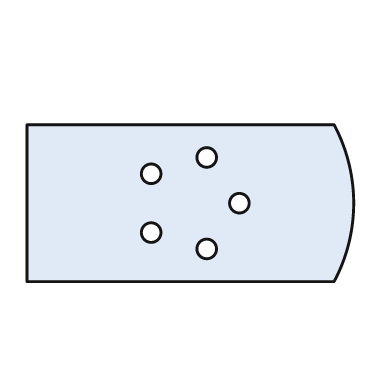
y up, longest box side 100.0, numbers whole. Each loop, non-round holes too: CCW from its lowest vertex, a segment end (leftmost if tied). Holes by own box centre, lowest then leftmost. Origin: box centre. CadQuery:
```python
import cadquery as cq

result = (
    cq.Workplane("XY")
    .moveTo(-50.0, -24.0)
    .lineTo(44.0, -24.0)
    .threePointArc((50.0, 0.0), (44.0, 24.0))
    .lineTo(-50.0, 24.0)
    .close()
    .moveTo(5.0, -14.0)
    .circle(3.0)
    .moveTo(-12.0, -9.0)
    .circle(3.0)
    .moveTo(15.0, 0.0)
    .circle(3.0)
    .moveTo(-12.0, 9.0)
    .circle(3.0)
    .moveTo(5.0, 14.0)
    .circle(3.0)
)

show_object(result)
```